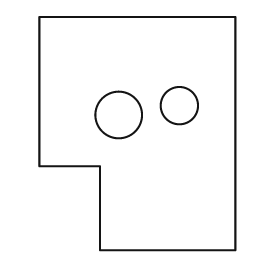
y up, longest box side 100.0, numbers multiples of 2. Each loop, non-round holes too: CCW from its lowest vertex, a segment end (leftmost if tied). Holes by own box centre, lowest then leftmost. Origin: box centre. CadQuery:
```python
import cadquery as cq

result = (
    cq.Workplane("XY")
    .moveTo(-16.0, -50.0)
    .lineTo(42.0, -50.0)
    .lineTo(42.0, 50.0)
    .lineTo(-42.0, 50.0)
    .lineTo(-42.0, -14.0)
    .lineTo(-16.0, -14.0)
    .close()
    .moveTo(-8.0, 8.0)
    .circle(10.0)
    .moveTo(18.0, 12.0)
    .circle(8.0)
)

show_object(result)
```